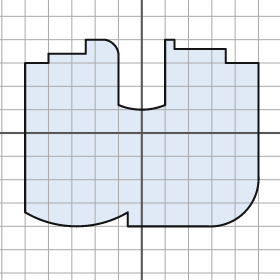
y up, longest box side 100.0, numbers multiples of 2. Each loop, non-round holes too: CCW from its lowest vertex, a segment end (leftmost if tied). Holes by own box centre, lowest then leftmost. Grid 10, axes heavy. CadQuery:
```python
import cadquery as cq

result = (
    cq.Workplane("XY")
    .moveTo(-6.0, -40.0)
    .lineTo(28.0, -40.0)
    .threePointArc((44.0, -34.0), (50.0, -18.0))
    .lineTo(50.0, 30.0)
    .lineTo(36.0, 30.0)
    .lineTo(36.0, 36.0)
    .lineTo(14.0, 36.0)
    .lineTo(14.0, 40.0)
    .lineTo(10.0, 40.0)
    .lineTo(10.0, 12.0)
    .threePointArc((0.0, 10.0), (-10.0, 12.0))
    .lineTo(-10.0, 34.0)
    .threePointArc((-12.0, 38.0), (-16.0, 40.0))
    .lineTo(-24.0, 40.0)
    .lineTo(-24.0, 34.0)
    .lineTo(-40.0, 34.0)
    .lineTo(-40.0, 30.0)
    .lineTo(-50.0, 30.0)
    .lineTo(-50.0, -34.0)
    .threePointArc((-28.0, -40.0), (-6.0, -34.0))
    .close()
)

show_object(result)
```